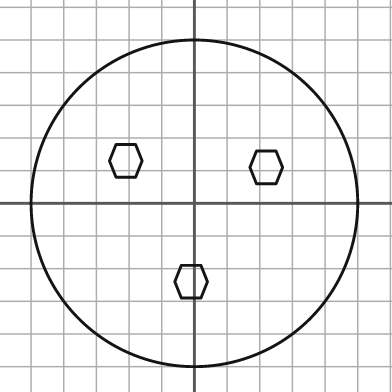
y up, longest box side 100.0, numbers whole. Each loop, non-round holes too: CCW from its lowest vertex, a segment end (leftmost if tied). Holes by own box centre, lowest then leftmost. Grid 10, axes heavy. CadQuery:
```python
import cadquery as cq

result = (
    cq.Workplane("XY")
    .moveTo(0.0, 0.0)
    .circle(50.0)
    .moveTo(-4.0, -29.0)
    .lineTo(2.0, -29.0)
    .lineTo(4.0, -24.0)
    .lineTo(2.0, -19.0)
    .lineTo(-4.0, -19.0)
    .lineTo(-6.0, -24.0)
    .close()
    .moveTo(19.0, 6.0)
    .lineTo(25.0, 6.0)
    .lineTo(27.0, 11.0)
    .lineTo(25.0, 16.0)
    .lineTo(19.0, 16.0)
    .lineTo(17.0, 11.0)
    .close()
    .moveTo(-24.0, 8.0)
    .lineTo(-18.0, 8.0)
    .lineTo(-16.0, 13.0)
    .lineTo(-18.0, 18.0)
    .lineTo(-24.0, 18.0)
    .lineTo(-26.0, 13.0)
    .close()
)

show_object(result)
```